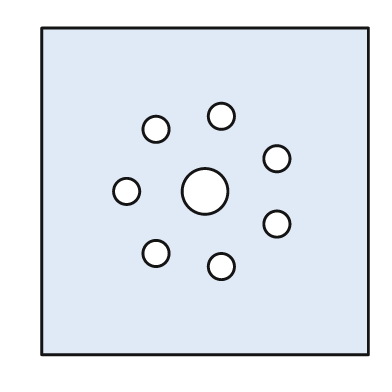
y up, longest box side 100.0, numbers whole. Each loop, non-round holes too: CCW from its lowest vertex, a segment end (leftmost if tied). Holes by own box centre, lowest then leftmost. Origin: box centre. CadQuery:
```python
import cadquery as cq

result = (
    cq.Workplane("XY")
    .moveTo(-50.0, -50.0)
    .lineTo(50.0, -50.0)
    .lineTo(50.0, 50.0)
    .lineTo(-50.0, 50.0)
    .close()
    .moveTo(5.0, -23.0)
    .circle(4.0)
    .moveTo(-15.0, -19.0)
    .circle(4.0)
    .moveTo(22.0, -10.0)
    .circle(4.0)
    .moveTo(-24.0, 0.0)
    .circle(4.0)
    .moveTo(0.0, 0.0)
    .circle(7.0)
    .moveTo(22.0, 10.0)
    .circle(4.0)
    .moveTo(-15.0, 19.0)
    .circle(4.0)
    .moveTo(5.0, 23.0)
    .circle(4.0)
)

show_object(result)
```